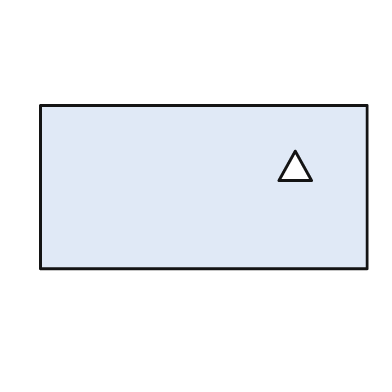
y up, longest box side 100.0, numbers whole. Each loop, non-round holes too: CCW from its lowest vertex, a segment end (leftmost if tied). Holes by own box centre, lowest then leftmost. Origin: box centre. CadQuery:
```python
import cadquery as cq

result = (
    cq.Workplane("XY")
    .moveTo(-50.0, -25.0)
    .lineTo(50.0, -25.0)
    .lineTo(50.0, 25.0)
    .lineTo(-50.0, 25.0)
    .close()
    .moveTo(23.0, 2.0)
    .lineTo(33.0, 2.0)
    .lineTo(28.0, 11.0)
    .close()
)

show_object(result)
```